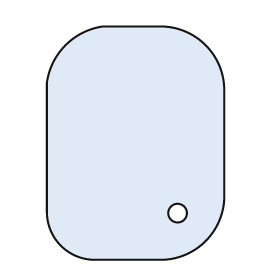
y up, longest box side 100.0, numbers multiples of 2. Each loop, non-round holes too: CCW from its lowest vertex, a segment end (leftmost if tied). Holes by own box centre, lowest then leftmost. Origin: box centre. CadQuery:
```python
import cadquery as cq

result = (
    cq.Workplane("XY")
    .moveTo(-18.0, -50.0)
    .lineTo(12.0, -50.0)
    .threePointArc((30.0, -42.0), (38.0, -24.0))
    .lineTo(38.0, 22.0)
    .threePointArc((30.0, 42.0), (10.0, 50.0))
    .lineTo(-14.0, 50.0)
    .threePointArc((-30.0, 42.0), (-38.0, 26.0))
    .lineTo(-38.0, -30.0)
    .threePointArc((-32.0, -44.0), (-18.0, -50.0))
    .close()
    .moveTo(18.0, -30.0)
    .circle(4.0)
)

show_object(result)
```